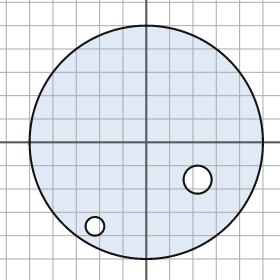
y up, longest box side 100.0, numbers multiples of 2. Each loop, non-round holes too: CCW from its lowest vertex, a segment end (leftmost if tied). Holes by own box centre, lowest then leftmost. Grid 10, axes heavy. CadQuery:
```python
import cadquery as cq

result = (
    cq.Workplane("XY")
    .moveTo(0.0, 0.0)
    .circle(50.0)
    .moveTo(-22.0, -36.0)
    .circle(4.0)
    .moveTo(22.0, -16.0)
    .circle(6.0)
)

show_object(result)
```